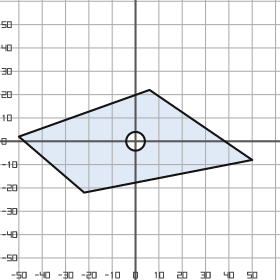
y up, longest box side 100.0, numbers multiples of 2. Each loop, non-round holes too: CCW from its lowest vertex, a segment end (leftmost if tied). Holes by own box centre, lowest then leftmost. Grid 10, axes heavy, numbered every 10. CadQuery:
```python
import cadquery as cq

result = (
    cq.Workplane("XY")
    .moveTo(-22.0, -22.0)
    .lineTo(50.0, -8.0)
    .lineTo(6.0, 22.0)
    .lineTo(-50.0, 2.0)
    .close()
    .moveTo(0.0, 0.0)
    .circle(4.0)
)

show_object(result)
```